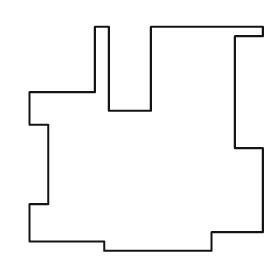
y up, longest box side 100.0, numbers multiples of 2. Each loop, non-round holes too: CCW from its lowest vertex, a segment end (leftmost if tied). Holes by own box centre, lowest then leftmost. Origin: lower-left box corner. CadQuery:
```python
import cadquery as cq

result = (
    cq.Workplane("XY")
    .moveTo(32.0, 0.0)
    .lineTo(78.0, 0.0)
    .lineTo(78.0, 8.0)
    .lineTo(100.0, 8.0)
    .lineTo(100.0, 44.0)
    .lineTo(88.0, 44.0)
    .lineTo(88.0, 92.0)
    .lineTo(100.0, 92.0)
    .lineTo(100.0, 96.0)
    .lineTo(52.0, 96.0)
    .lineTo(52.0, 60.0)
    .lineTo(34.0, 60.0)
    .lineTo(34.0, 96.0)
    .lineTo(28.0, 96.0)
    .lineTo(28.0, 68.0)
    .lineTo(0.0, 68.0)
    .lineTo(0.0, 54.0)
    .lineTo(8.0, 54.0)
    .lineTo(8.0, 20.0)
    .lineTo(0.0, 20.0)
    .lineTo(0.0, 4.0)
    .lineTo(32.0, 4.0)
    .close()
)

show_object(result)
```